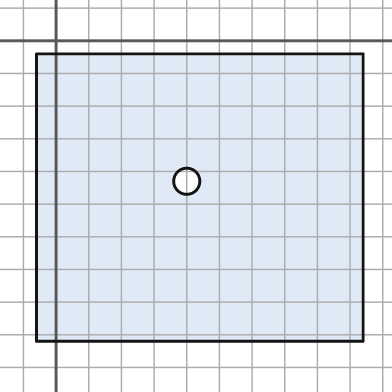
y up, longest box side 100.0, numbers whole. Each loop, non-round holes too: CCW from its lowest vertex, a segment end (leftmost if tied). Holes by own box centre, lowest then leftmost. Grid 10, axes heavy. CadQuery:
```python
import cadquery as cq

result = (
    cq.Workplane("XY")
    .moveTo(-6.0, -92.0)
    .lineTo(94.0, -92.0)
    .lineTo(94.0, -4.0)
    .lineTo(-6.0, -4.0)
    .close()
    .moveTo(40.0, -43.0)
    .circle(4.0)
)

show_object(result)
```